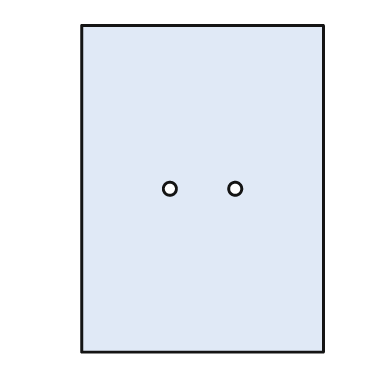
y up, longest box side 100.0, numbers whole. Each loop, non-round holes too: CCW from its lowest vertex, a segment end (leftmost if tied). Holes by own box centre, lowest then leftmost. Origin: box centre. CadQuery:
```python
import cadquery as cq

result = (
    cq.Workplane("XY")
    .moveTo(-37.0, -50.0)
    .lineTo(37.0, -50.0)
    .lineTo(37.0, 50.0)
    .lineTo(-37.0, 50.0)
    .close()
    .moveTo(-10.0, 0.0)
    .circle(2.0)
    .moveTo(10.0, 0.0)
    .circle(2.0)
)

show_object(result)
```